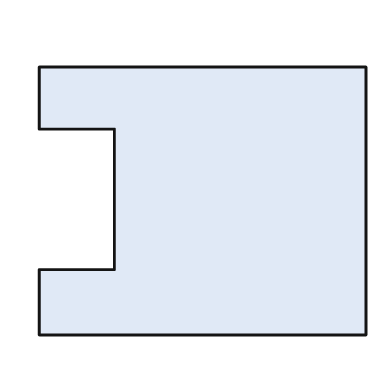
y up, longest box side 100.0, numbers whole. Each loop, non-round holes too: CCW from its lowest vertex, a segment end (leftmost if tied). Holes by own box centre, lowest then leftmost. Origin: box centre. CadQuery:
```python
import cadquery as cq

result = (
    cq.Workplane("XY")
    .moveTo(-50.0, -41.0)
    .lineTo(50.0, -41.0)
    .lineTo(50.0, 41.0)
    .lineTo(-50.0, 41.0)
    .lineTo(-50.0, 22.0)
    .lineTo(-27.0, 22.0)
    .lineTo(-27.0, -21.0)
    .lineTo(-50.0, -21.0)
    .close()
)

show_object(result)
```